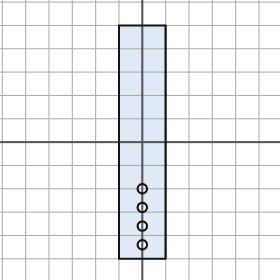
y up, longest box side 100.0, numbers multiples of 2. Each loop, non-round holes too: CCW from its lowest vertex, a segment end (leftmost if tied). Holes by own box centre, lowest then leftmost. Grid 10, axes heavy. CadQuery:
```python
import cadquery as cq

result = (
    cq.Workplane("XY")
    .moveTo(-10.0, -50.0)
    .lineTo(10.0, -50.0)
    .lineTo(10.0, 50.0)
    .lineTo(-10.0, 50.0)
    .close()
    .moveTo(0.0, -44.0)
    .circle(2.0)
    .moveTo(0.0, -36.0)
    .circle(2.0)
    .moveTo(0.0, -28.0)
    .circle(2.0)
    .moveTo(0.0, -20.0)
    .circle(2.0)
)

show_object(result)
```